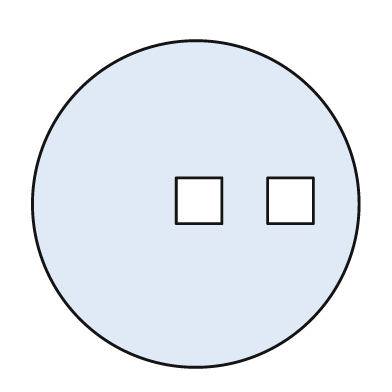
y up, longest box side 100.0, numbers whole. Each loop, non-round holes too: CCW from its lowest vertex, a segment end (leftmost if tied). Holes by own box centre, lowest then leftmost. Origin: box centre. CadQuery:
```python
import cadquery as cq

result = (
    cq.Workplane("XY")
    .moveTo(0.0, 0.0)
    .circle(50.0)
    .moveTo(-6.0, -6.0)
    .lineTo(8.0, -6.0)
    .lineTo(8.0, 8.0)
    .lineTo(-6.0, 8.0)
    .close()
    .moveTo(22.0, -6.0)
    .lineTo(36.0, -6.0)
    .lineTo(36.0, 8.0)
    .lineTo(22.0, 8.0)
    .close()
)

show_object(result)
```